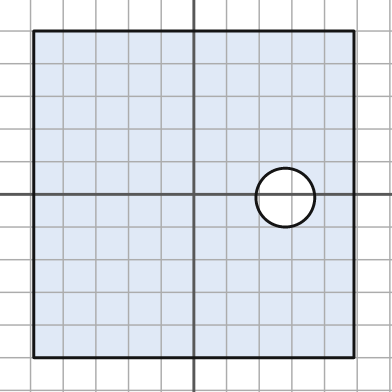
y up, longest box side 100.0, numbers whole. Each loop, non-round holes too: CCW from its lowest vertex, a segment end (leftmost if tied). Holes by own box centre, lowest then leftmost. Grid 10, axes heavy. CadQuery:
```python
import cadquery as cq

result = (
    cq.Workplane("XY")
    .moveTo(-49.0, -50.0)
    .lineTo(49.0, -50.0)
    .lineTo(49.0, 50.0)
    .lineTo(-49.0, 50.0)
    .close()
    .moveTo(28.0, -1.0)
    .circle(9.0)
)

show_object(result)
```